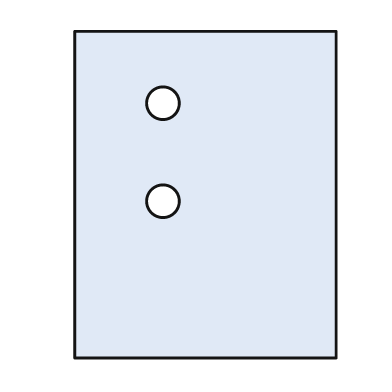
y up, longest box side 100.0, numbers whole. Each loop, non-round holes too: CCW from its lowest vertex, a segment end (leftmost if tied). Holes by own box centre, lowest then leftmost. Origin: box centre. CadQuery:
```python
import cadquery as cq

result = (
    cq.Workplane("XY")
    .moveTo(-40.0, -50.0)
    .lineTo(40.0, -50.0)
    .lineTo(40.0, 50.0)
    .lineTo(-40.0, 50.0)
    .close()
    .moveTo(-13.0, -2.0)
    .circle(5.0)
    .moveTo(-13.0, 28.0)
    .circle(5.0)
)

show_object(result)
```